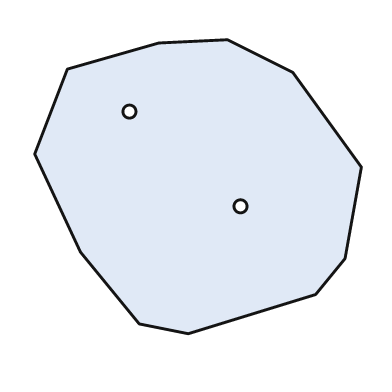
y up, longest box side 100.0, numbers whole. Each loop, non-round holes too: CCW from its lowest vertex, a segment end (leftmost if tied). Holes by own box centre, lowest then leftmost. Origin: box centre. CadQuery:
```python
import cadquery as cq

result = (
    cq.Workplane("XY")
    .moveTo(-3.0, -45.0)
    .lineTo(36.0, -33.0)
    .lineTo(45.0, -22.0)
    .lineTo(50.0, 6.0)
    .lineTo(29.0, 35.0)
    .lineTo(9.0, 45.0)
    .lineTo(-12.0, 44.0)
    .lineTo(-40.0, 36.0)
    .lineTo(-50.0, 10.0)
    .lineTo(-36.0, -20.0)
    .lineTo(-18.0, -42.0)
    .close()
    .moveTo(13.0, -6.0)
    .circle(2.0)
    .moveTo(-21.0, 23.0)
    .circle(2.0)
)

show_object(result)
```